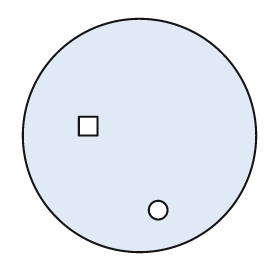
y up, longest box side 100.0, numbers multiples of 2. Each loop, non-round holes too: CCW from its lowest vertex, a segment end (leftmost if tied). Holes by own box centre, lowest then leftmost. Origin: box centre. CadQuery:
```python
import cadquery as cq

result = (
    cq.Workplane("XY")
    .moveTo(0.0, 0.0)
    .circle(50.0)
    .moveTo(8.0, -32.0)
    .circle(4.0)
    .moveTo(-26.0, 0.0)
    .lineTo(-18.0, 0.0)
    .lineTo(-18.0, 8.0)
    .lineTo(-26.0, 8.0)
    .close()
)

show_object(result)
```